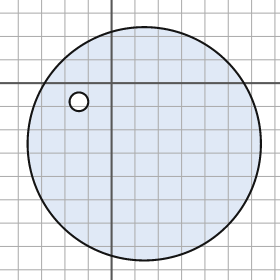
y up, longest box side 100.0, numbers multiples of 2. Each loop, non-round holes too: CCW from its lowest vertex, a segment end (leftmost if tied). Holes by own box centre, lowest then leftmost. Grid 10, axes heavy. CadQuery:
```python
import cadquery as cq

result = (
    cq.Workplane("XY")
    .moveTo(14.0, -26.0)
    .circle(50.0)
    .moveTo(-14.0, -8.0)
    .circle(4.0)
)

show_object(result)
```